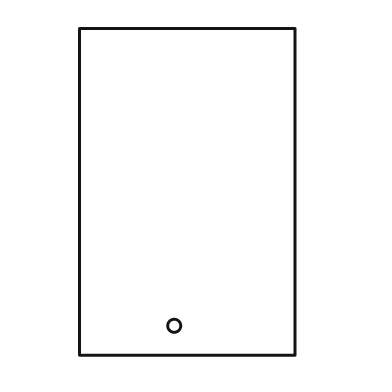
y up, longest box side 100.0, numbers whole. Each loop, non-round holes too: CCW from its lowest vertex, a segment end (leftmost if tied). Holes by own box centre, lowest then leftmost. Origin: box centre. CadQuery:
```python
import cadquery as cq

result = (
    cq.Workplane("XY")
    .moveTo(-33.0, -50.0)
    .lineTo(33.0, -50.0)
    .lineTo(33.0, 50.0)
    .lineTo(-33.0, 50.0)
    .close()
    .moveTo(-4.0, -41.0)
    .circle(2.0)
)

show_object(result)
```